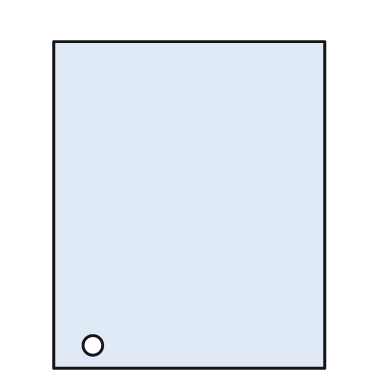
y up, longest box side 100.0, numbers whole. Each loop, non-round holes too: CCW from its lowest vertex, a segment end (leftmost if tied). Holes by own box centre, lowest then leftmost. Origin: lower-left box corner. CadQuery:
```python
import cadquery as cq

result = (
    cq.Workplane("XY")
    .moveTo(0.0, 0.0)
    .lineTo(83.0, 0.0)
    .lineTo(83.0, 100.0)
    .lineTo(0.0, 100.0)
    .close()
    .moveTo(12.0, 7.0)
    .circle(3.0)
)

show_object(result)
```